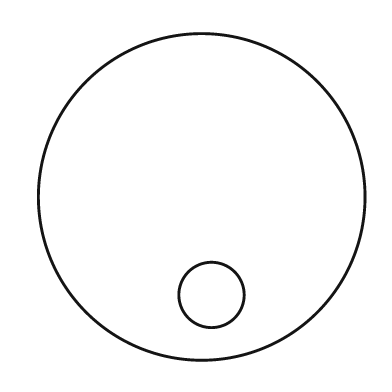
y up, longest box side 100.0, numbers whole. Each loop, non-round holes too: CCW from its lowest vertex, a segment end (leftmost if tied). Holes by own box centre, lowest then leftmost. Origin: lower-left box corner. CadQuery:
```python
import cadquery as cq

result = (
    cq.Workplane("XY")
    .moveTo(50.0, 50.0)
    .circle(50.0)
    .moveTo(53.0, 20.0)
    .circle(10.0)
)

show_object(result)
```